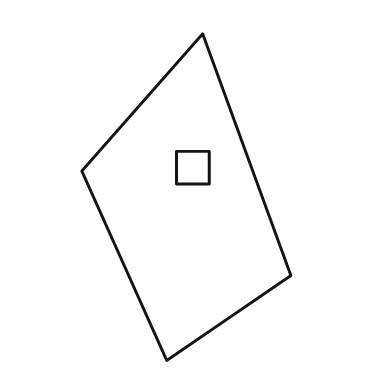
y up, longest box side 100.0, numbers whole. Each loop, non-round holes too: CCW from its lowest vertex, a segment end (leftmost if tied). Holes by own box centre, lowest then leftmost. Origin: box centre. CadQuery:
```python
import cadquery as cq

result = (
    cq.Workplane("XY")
    .moveTo(-6.0, -50.0)
    .lineTo(32.0, -24.0)
    .lineTo(5.0, 50.0)
    .lineTo(-32.0, 8.0)
    .close()
    .moveTo(-3.0, 4.0)
    .lineTo(7.0, 4.0)
    .lineTo(7.0, 14.0)
    .lineTo(-3.0, 14.0)
    .close()
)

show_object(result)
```